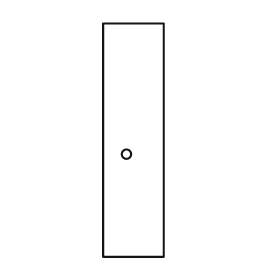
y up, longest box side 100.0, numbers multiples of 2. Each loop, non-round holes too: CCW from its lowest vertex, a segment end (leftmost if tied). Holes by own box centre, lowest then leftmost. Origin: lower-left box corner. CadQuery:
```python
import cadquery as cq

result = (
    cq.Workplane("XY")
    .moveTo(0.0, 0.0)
    .lineTo(26.0, 0.0)
    .lineTo(26.0, 100.0)
    .lineTo(0.0, 100.0)
    .close()
    .moveTo(10.0, 44.0)
    .circle(2.0)
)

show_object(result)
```